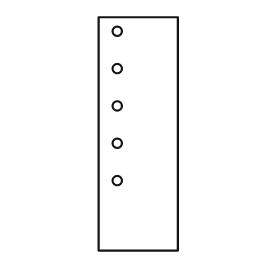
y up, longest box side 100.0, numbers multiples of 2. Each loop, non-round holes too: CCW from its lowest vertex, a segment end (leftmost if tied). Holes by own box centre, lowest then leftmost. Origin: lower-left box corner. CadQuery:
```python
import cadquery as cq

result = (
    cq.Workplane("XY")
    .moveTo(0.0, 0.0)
    .lineTo(34.0, 0.0)
    .lineTo(34.0, 100.0)
    .lineTo(0.0, 100.0)
    .close()
    .moveTo(8.0, 30.0)
    .circle(2.0)
    .moveTo(8.0, 46.0)
    .circle(2.0)
    .moveTo(8.0, 62.0)
    .circle(2.0)
    .moveTo(8.0, 78.0)
    .circle(2.0)
    .moveTo(8.0, 94.0)
    .circle(2.0)
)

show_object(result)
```